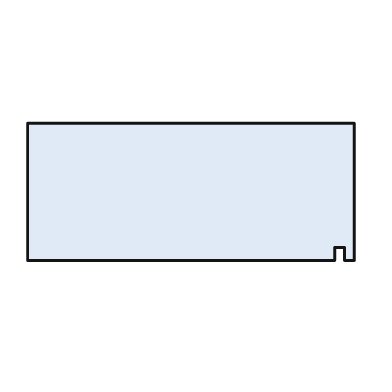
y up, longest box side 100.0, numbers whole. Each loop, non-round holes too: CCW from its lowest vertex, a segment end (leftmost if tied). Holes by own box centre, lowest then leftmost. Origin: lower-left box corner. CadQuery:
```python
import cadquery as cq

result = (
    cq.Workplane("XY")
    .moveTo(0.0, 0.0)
    .lineTo(94.0, 0.0)
    .lineTo(94.0, 4.0)
    .lineTo(97.0, 4.0)
    .lineTo(97.0, 0.0)
    .lineTo(100.0, 0.0)
    .lineTo(100.0, 42.0)
    .lineTo(0.0, 42.0)
    .close()
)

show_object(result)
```